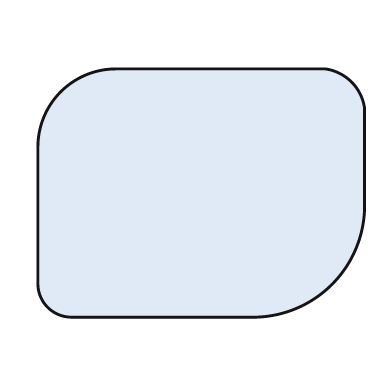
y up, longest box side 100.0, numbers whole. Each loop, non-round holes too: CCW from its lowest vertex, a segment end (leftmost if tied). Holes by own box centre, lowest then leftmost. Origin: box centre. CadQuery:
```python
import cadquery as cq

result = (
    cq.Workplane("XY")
    .moveTo(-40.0, -38.0)
    .lineTo(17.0, -38.0)
    .threePointArc((40.0, -28.0), (50.0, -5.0))
    .lineTo(50.0, 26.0)
    .threePointArc((46.0, 34.0), (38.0, 38.0))
    .lineTo(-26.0, 38.0)
    .threePointArc((-43.0, 31.0), (-50.0, 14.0))
    .lineTo(-50.0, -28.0)
    .threePointArc((-47.0, -35.0), (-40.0, -38.0))
    .close()
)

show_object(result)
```